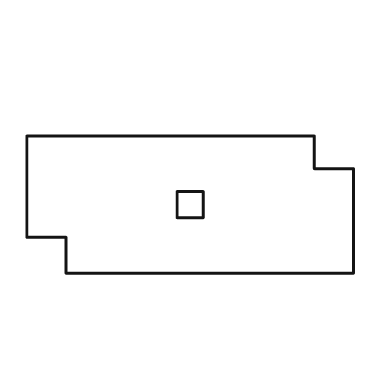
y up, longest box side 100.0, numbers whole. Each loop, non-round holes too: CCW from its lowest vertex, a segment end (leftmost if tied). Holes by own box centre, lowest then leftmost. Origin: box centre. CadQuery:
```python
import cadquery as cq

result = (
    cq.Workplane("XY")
    .moveTo(-38.0, -21.0)
    .lineTo(50.0, -21.0)
    .lineTo(50.0, 11.0)
    .lineTo(38.0, 11.0)
    .lineTo(38.0, 21.0)
    .lineTo(-50.0, 21.0)
    .lineTo(-50.0, -10.0)
    .lineTo(-38.0, -10.0)
    .close()
    .moveTo(-4.0, -4.0)
    .lineTo(4.0, -4.0)
    .lineTo(4.0, 4.0)
    .lineTo(-4.0, 4.0)
    .close()
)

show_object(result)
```